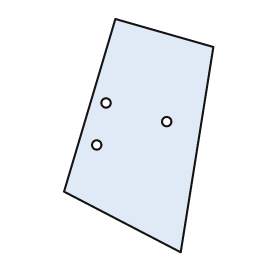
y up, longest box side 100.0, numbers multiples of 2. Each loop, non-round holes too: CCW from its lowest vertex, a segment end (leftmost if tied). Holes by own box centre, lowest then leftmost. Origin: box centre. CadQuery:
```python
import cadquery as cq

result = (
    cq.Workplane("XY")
    .moveTo(18.0, -50.0)
    .lineTo(32.0, 38.0)
    .lineTo(-10.0, 50.0)
    .lineTo(-32.0, -24.0)
    .close()
    .moveTo(-18.0, -4.0)
    .circle(2.0)
    .moveTo(12.0, 6.0)
    .circle(2.0)
    .moveTo(-14.0, 14.0)
    .circle(2.0)
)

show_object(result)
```